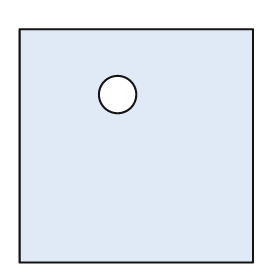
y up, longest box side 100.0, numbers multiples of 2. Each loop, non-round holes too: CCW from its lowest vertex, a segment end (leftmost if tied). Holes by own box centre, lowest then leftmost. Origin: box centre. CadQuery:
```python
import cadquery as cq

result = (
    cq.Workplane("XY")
    .moveTo(-50.0, -50.0)
    .lineTo(50.0, -50.0)
    .lineTo(50.0, 50.0)
    .lineTo(-50.0, 50.0)
    .close()
    .moveTo(-8.0, 22.0)
    .circle(8.0)
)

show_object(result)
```